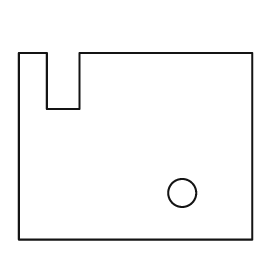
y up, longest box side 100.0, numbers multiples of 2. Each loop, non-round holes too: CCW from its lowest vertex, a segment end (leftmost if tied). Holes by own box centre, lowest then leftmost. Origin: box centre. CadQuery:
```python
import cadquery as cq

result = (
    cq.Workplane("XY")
    .moveTo(-50.0, -40.0)
    .lineTo(50.0, -40.0)
    .lineTo(50.0, 40.0)
    .lineTo(-24.0, 40.0)
    .lineTo(-24.0, 16.0)
    .lineTo(-38.0, 16.0)
    .lineTo(-38.0, 40.0)
    .lineTo(-50.0, 40.0)
    .close()
    .moveTo(20.0, -20.0)
    .circle(6.0)
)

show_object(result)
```